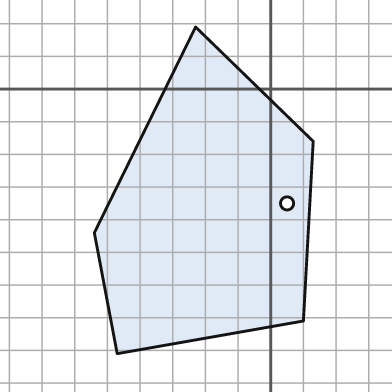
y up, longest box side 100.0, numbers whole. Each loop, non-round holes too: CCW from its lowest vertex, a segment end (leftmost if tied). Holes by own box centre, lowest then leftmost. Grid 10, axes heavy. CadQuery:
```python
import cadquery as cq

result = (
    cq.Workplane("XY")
    .moveTo(-47.0, -81.0)
    .lineTo(10.0, -71.0)
    .lineTo(13.0, -16.0)
    .lineTo(-23.0, 19.0)
    .lineTo(-54.0, -44.0)
    .close()
    .moveTo(5.0, -35.0)
    .circle(2.0)
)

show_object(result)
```